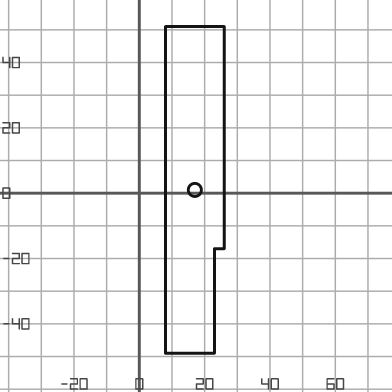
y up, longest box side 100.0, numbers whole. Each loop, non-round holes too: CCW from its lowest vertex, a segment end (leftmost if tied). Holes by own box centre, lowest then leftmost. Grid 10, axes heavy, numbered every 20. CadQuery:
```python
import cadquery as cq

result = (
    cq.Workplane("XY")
    .moveTo(8.0, -49.0)
    .lineTo(23.0, -49.0)
    .lineTo(23.0, -17.0)
    .lineTo(26.0, -17.0)
    .lineTo(26.0, 51.0)
    .lineTo(8.0, 51.0)
    .close()
    .moveTo(17.0, 1.0)
    .circle(2.0)
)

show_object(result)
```